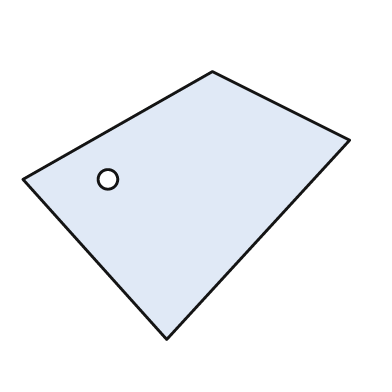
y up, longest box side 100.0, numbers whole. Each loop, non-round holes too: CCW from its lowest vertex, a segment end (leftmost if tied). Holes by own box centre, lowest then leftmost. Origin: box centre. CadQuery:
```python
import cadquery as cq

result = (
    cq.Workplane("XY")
    .moveTo(-6.0, -41.0)
    .lineTo(50.0, 20.0)
    .lineTo(8.0, 41.0)
    .lineTo(-50.0, 8.0)
    .close()
    .moveTo(-24.0, 8.0)
    .circle(3.0)
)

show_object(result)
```